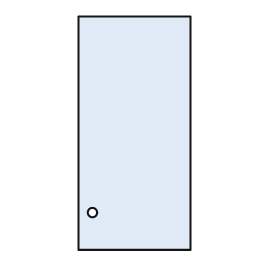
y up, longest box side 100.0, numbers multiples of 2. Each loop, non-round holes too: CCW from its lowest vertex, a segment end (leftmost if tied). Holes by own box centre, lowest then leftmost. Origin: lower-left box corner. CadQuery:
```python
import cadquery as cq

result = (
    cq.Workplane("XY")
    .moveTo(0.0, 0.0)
    .lineTo(48.0, 0.0)
    .lineTo(48.0, 100.0)
    .lineTo(0.0, 100.0)
    .close()
    .moveTo(6.0, 16.0)
    .circle(2.0)
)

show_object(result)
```